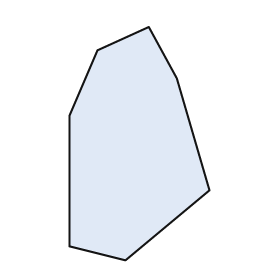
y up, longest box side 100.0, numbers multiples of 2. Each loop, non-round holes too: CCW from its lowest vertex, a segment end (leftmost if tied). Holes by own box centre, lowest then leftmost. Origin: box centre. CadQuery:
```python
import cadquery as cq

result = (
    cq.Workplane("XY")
    .moveTo(-6.0, -50.0)
    .lineTo(30.0, -20.0)
    .lineTo(16.0, 28.0)
    .lineTo(4.0, 50.0)
    .lineTo(-18.0, 40.0)
    .lineTo(-30.0, 12.0)
    .lineTo(-30.0, -44.0)
    .close()
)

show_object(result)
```